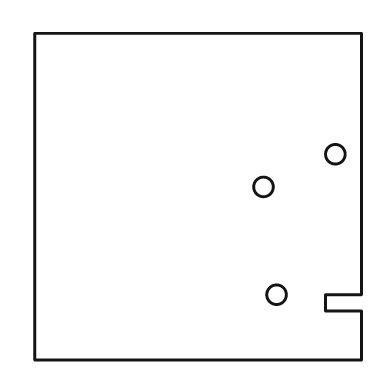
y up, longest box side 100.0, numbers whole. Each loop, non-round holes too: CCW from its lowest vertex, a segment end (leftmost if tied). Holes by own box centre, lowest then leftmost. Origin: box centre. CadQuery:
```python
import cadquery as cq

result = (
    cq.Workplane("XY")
    .moveTo(-50.0, -50.0)
    .lineTo(50.0, -50.0)
    .lineTo(50.0, -35.0)
    .lineTo(39.0, -35.0)
    .lineTo(39.0, -30.0)
    .lineTo(50.0, -30.0)
    .lineTo(50.0, 50.0)
    .lineTo(-50.0, 50.0)
    .close()
    .moveTo(24.0, -30.0)
    .circle(3.0)
    .moveTo(20.0, 3.0)
    .circle(3.0)
    .moveTo(42.0, 13.0)
    .circle(3.0)
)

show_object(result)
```